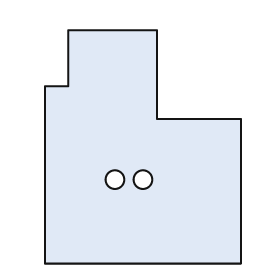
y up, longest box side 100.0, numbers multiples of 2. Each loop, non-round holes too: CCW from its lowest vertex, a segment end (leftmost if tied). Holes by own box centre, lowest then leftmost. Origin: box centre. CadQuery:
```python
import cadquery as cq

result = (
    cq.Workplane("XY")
    .moveTo(-42.0, -50.0)
    .lineTo(42.0, -50.0)
    .lineTo(42.0, 12.0)
    .lineTo(6.0, 12.0)
    .lineTo(6.0, 50.0)
    .lineTo(-32.0, 50.0)
    .lineTo(-32.0, 26.0)
    .lineTo(-42.0, 26.0)
    .close()
    .moveTo(-12.0, -14.0)
    .circle(4.0)
    .moveTo(0.0, -14.0)
    .circle(4.0)
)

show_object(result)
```